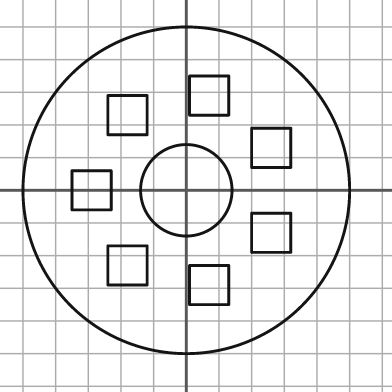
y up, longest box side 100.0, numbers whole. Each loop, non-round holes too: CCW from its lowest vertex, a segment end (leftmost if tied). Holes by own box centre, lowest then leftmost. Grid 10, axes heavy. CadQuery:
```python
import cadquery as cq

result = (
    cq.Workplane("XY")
    .moveTo(0.0, 0.0)
    .circle(50.0)
    .moveTo(1.0, -35.0)
    .lineTo(13.0, -35.0)
    .lineTo(13.0, -23.0)
    .lineTo(1.0, -23.0)
    .close()
    .moveTo(-24.0, -29.0)
    .lineTo(-12.0, -29.0)
    .lineTo(-12.0, -17.0)
    .lineTo(-24.0, -17.0)
    .close()
    .moveTo(20.0, -19.0)
    .lineTo(32.0, -19.0)
    .lineTo(32.0, -7.0)
    .lineTo(20.0, -7.0)
    .close()
    .moveTo(-35.0, -6.0)
    .lineTo(-23.0, -6.0)
    .lineTo(-23.0, 6.0)
    .lineTo(-35.0, 6.0)
    .close()
    .moveTo(0.0, 0.0)
    .circle(14.0)
    .moveTo(20.0, 7.0)
    .lineTo(32.0, 7.0)
    .lineTo(32.0, 19.0)
    .lineTo(20.0, 19.0)
    .close()
    .moveTo(-24.0, 17.0)
    .lineTo(-12.0, 17.0)
    .lineTo(-12.0, 29.0)
    .lineTo(-24.0, 29.0)
    .close()
    .moveTo(1.0, 23.0)
    .lineTo(13.0, 23.0)
    .lineTo(13.0, 35.0)
    .lineTo(1.0, 35.0)
    .close()
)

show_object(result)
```